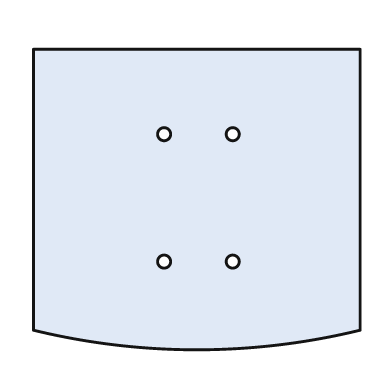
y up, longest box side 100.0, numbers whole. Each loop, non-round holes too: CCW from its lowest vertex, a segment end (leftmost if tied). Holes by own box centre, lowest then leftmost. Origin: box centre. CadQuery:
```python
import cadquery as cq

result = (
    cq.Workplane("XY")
    .moveTo(-50.0, -40.0)
    .threePointArc((0.0, -46.0), (50.0, -40.0))
    .lineTo(50.0, 46.0)
    .lineTo(-50.0, 46.0)
    .close()
    .moveTo(-10.0, -19.0)
    .circle(2.0)
    .moveTo(11.0, -19.0)
    .circle(2.0)
    .moveTo(-10.0, 20.0)
    .circle(2.0)
    .moveTo(11.0, 20.0)
    .circle(2.0)
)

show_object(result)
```